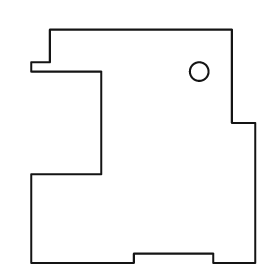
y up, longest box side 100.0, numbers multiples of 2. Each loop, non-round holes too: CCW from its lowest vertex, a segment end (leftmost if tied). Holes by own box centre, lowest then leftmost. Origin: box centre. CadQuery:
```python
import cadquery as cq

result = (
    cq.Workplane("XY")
    .moveTo(-48.0, -50.0)
    .lineTo(-4.0, -50.0)
    .lineTo(-4.0, -46.0)
    .lineTo(30.0, -46.0)
    .lineTo(30.0, -50.0)
    .lineTo(48.0, -50.0)
    .lineTo(48.0, 10.0)
    .lineTo(38.0, 10.0)
    .lineTo(38.0, 50.0)
    .lineTo(-40.0, 50.0)
    .lineTo(-40.0, 36.0)
    .lineTo(-48.0, 36.0)
    .lineTo(-48.0, 32.0)
    .lineTo(-18.0, 32.0)
    .lineTo(-18.0, -12.0)
    .lineTo(-48.0, -12.0)
    .close()
    .moveTo(24.0, 32.0)
    .circle(4.0)
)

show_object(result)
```